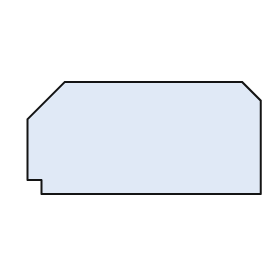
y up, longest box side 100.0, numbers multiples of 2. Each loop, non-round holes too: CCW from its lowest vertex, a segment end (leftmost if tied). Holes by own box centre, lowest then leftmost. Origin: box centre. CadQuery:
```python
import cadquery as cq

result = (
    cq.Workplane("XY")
    .moveTo(-44.0, -24.0)
    .lineTo(50.0, -24.0)
    .lineTo(50.0, 16.0)
    .lineTo(42.0, 24.0)
    .lineTo(-34.0, 24.0)
    .lineTo(-50.0, 8.0)
    .lineTo(-50.0, -18.0)
    .lineTo(-44.0, -18.0)
    .close()
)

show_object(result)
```